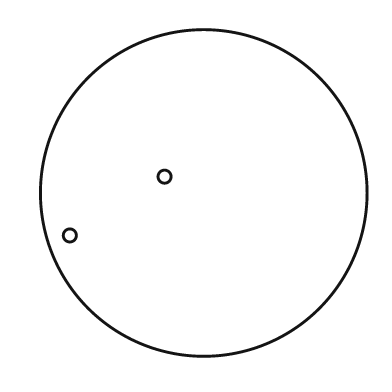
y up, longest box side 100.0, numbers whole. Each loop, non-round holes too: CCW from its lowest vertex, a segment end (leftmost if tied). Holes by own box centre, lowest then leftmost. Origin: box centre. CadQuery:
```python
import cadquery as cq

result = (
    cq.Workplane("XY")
    .moveTo(0.0, 0.0)
    .circle(50.0)
    .moveTo(-41.0, -13.0)
    .circle(2.0)
    .moveTo(-12.0, 5.0)
    .circle(2.0)
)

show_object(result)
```